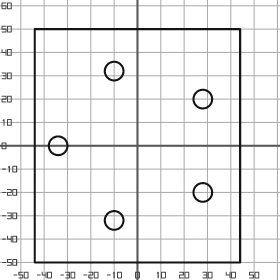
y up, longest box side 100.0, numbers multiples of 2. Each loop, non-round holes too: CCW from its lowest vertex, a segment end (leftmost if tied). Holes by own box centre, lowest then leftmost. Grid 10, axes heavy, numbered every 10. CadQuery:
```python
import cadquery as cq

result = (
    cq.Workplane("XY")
    .moveTo(-44.0, -50.0)
    .lineTo(44.0, -50.0)
    .lineTo(44.0, 50.0)
    .lineTo(-44.0, 50.0)
    .close()
    .moveTo(-10.0, -32.0)
    .circle(4.0)
    .moveTo(28.0, -20.0)
    .circle(4.0)
    .moveTo(-34.0, 0.0)
    .circle(4.0)
    .moveTo(28.0, 20.0)
    .circle(4.0)
    .moveTo(-10.0, 32.0)
    .circle(4.0)
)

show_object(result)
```